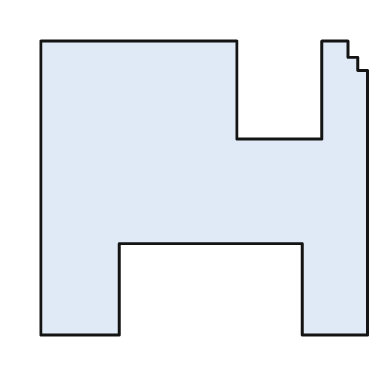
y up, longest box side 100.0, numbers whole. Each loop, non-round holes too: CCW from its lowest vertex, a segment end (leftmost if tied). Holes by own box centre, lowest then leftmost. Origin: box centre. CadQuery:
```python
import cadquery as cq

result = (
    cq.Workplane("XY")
    .moveTo(-50.0, -45.0)
    .lineTo(-26.0, -45.0)
    .lineTo(-26.0, -17.0)
    .lineTo(30.0, -17.0)
    .lineTo(30.0, -45.0)
    .lineTo(50.0, -45.0)
    .lineTo(50.0, 36.0)
    .lineTo(47.0, 36.0)
    .lineTo(47.0, 40.0)
    .lineTo(44.0, 40.0)
    .lineTo(44.0, 45.0)
    .lineTo(36.0, 45.0)
    .lineTo(36.0, 15.0)
    .lineTo(10.0, 15.0)
    .lineTo(10.0, 45.0)
    .lineTo(-50.0, 45.0)
    .close()
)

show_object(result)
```